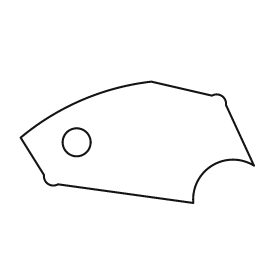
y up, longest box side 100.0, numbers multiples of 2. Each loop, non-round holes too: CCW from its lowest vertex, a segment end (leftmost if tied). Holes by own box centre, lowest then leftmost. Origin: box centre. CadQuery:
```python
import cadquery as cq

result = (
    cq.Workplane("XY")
    .moveTo(24.0, -26.0)
    .threePointArc((32.0, -10.0), (50.0, -10.0))
    .lineTo(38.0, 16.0)
    .threePointArc((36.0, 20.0), (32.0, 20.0))
    .lineTo(6.0, 26.0)
    .threePointArc((-24.0, 18.0), (-50.0, 2.0))
    .lineTo(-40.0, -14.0)
    .threePointArc((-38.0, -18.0), (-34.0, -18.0))
    .close()
    .moveTo(-26.0, 0.0)
    .circle(6.0)
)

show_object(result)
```